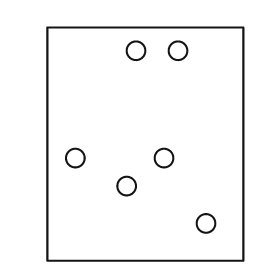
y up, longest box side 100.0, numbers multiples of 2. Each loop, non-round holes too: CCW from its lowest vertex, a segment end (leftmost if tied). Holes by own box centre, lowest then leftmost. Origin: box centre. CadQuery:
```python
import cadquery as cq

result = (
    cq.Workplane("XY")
    .moveTo(-42.0, -50.0)
    .lineTo(42.0, -50.0)
    .lineTo(42.0, 50.0)
    .lineTo(-42.0, 50.0)
    .close()
    .moveTo(26.0, -34.0)
    .circle(4.0)
    .moveTo(-8.0, -18.0)
    .circle(4.0)
    .moveTo(-30.0, -6.0)
    .circle(4.0)
    .moveTo(8.0, -6.0)
    .circle(4.0)
    .moveTo(-4.0, 40.0)
    .circle(4.0)
    .moveTo(14.0, 40.0)
    .circle(4.0)
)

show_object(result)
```